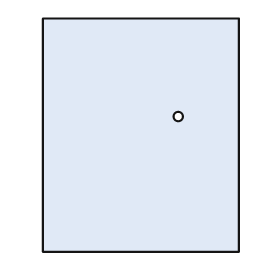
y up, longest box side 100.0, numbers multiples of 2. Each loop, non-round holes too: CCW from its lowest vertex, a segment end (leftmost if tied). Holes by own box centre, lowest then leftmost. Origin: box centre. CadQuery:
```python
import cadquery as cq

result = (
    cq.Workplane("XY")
    .moveTo(-42.0, -50.0)
    .lineTo(42.0, -50.0)
    .lineTo(42.0, 50.0)
    .lineTo(-42.0, 50.0)
    .close()
    .moveTo(16.0, 8.0)
    .circle(2.0)
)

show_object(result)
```